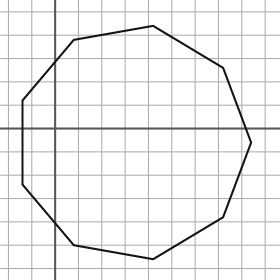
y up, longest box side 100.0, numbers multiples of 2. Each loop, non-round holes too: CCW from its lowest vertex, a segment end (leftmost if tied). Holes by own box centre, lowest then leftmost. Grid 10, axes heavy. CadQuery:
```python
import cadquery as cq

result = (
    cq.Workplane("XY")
    .moveTo(42.0, -56.0)
    .lineTo(72.0, -38.0)
    .lineTo(84.0, -6.0)
    .lineTo(72.0, 26.0)
    .lineTo(42.0, 44.0)
    .lineTo(8.0, 38.0)
    .lineTo(-14.0, 12.0)
    .lineTo(-14.0, -24.0)
    .lineTo(8.0, -50.0)
    .close()
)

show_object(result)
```